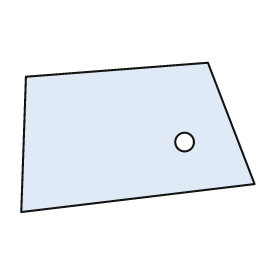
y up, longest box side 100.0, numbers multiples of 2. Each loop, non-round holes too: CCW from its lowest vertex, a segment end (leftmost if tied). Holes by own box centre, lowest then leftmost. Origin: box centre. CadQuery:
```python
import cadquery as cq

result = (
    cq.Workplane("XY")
    .moveTo(-50.0, -32.0)
    .lineTo(50.0, -20.0)
    .lineTo(30.0, 32.0)
    .lineTo(-48.0, 26.0)
    .close()
    .moveTo(20.0, -2.0)
    .circle(4.0)
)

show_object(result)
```